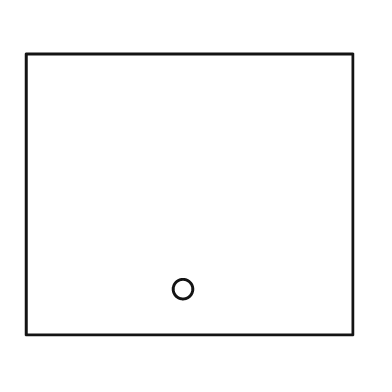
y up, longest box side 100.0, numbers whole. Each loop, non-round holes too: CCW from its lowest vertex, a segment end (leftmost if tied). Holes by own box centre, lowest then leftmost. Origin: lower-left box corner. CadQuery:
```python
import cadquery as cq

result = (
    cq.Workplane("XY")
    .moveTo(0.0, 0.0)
    .lineTo(100.0, 0.0)
    .lineTo(100.0, 86.0)
    .lineTo(0.0, 86.0)
    .close()
    .moveTo(48.0, 14.0)
    .circle(3.0)
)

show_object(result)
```